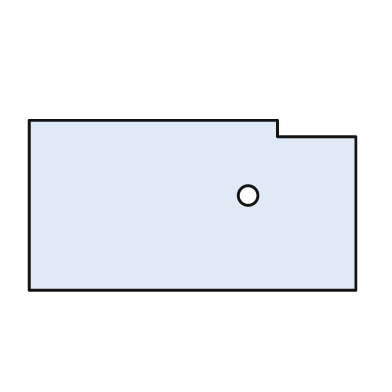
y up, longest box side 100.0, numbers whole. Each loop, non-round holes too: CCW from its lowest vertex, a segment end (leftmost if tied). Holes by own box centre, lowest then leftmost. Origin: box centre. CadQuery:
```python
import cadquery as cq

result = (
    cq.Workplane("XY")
    .moveTo(-50.0, -26.0)
    .lineTo(50.0, -26.0)
    .lineTo(50.0, 21.0)
    .lineTo(26.0, 21.0)
    .lineTo(26.0, 26.0)
    .lineTo(-50.0, 26.0)
    .close()
    .moveTo(17.0, 3.0)
    .circle(3.0)
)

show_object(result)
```